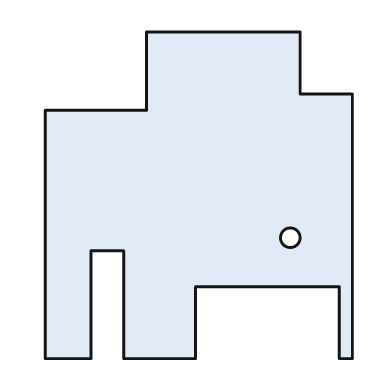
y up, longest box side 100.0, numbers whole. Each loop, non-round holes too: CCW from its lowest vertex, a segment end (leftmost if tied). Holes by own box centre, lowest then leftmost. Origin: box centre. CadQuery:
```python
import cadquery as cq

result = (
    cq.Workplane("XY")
    .moveTo(-47.0, -50.0)
    .lineTo(-33.0, -50.0)
    .lineTo(-33.0, -17.0)
    .lineTo(-23.0, -17.0)
    .lineTo(-23.0, -50.0)
    .lineTo(-1.0, -50.0)
    .lineTo(-1.0, -28.0)
    .lineTo(43.0, -28.0)
    .lineTo(43.0, -50.0)
    .lineTo(47.0, -50.0)
    .lineTo(47.0, 31.0)
    .lineTo(31.0, 31.0)
    .lineTo(31.0, 50.0)
    .lineTo(-16.0, 50.0)
    .lineTo(-16.0, 26.0)
    .lineTo(-47.0, 26.0)
    .close()
    .moveTo(28.0, -13.0)
    .circle(3.0)
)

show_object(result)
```